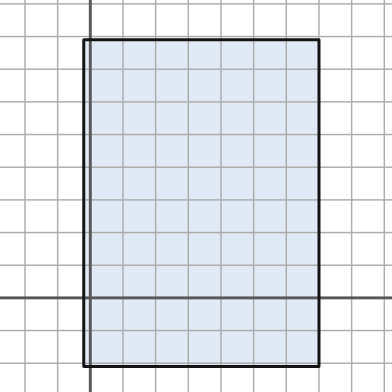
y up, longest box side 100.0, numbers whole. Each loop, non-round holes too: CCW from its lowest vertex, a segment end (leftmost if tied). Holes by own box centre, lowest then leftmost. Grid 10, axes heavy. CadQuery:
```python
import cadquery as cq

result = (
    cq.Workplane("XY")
    .moveTo(-2.0, -21.0)
    .lineTo(70.0, -21.0)
    .lineTo(70.0, 79.0)
    .lineTo(-2.0, 79.0)
    .close()
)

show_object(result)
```